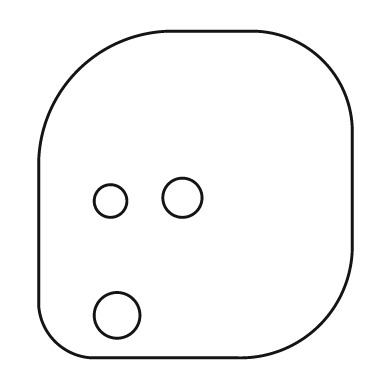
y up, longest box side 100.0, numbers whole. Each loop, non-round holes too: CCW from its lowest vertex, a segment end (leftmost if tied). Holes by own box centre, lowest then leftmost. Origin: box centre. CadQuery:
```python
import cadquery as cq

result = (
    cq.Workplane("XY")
    .moveTo(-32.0, -50.0)
    .lineTo(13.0, -50.0)
    .threePointArc((38.0, -40.0), (48.0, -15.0))
    .lineTo(48.0, 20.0)
    .threePointArc((39.0, 41.0), (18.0, 50.0))
    .lineTo(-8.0, 50.0)
    .threePointArc((-36.0, 38.0), (-48.0, 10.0))
    .lineTo(-48.0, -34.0)
    .threePointArc((-43.0, -45.0), (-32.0, -50.0))
    .close()
    .moveTo(-24.0, -37.0)
    .circle(7.0)
    .moveTo(-26.0, -2.0)
    .circle(5.0)
    .moveTo(-4.0, -1.0)
    .circle(6.0)
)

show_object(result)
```